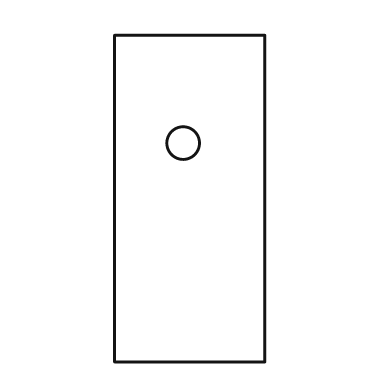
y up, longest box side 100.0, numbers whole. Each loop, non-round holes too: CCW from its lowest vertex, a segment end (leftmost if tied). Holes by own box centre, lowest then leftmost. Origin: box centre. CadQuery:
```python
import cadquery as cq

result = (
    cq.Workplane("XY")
    .moveTo(-23.0, -50.0)
    .lineTo(23.0, -50.0)
    .lineTo(23.0, 50.0)
    .lineTo(-23.0, 50.0)
    .close()
    .moveTo(-2.0, 17.0)
    .circle(5.0)
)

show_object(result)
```